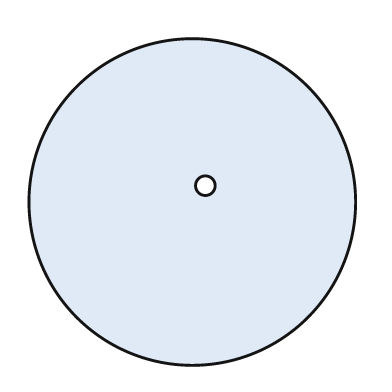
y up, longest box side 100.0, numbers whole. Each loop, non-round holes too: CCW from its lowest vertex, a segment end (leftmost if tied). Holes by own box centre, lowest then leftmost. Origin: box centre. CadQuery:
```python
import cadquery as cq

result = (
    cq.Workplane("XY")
    .moveTo(0.0, 0.0)
    .circle(50.0)
    .moveTo(4.0, 5.0)
    .circle(3.0)
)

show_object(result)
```